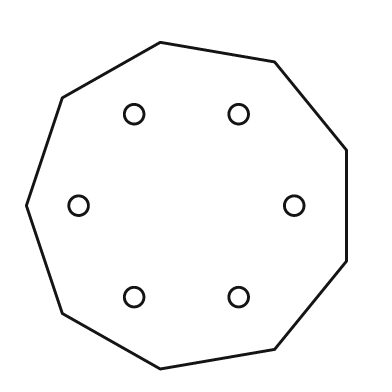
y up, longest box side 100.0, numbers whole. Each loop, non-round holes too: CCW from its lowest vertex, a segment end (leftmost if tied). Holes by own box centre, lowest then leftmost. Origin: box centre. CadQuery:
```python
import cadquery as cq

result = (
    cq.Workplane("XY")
    .moveTo(-8.0, -50.0)
    .lineTo(27.0, -44.0)
    .lineTo(49.0, -17.0)
    .lineTo(49.0, 17.0)
    .lineTo(27.0, 44.0)
    .lineTo(-8.0, 50.0)
    .lineTo(-38.0, 33.0)
    .lineTo(-49.0, 0.0)
    .lineTo(-38.0, -33.0)
    .close()
    .moveTo(-16.0, -28.0)
    .circle(3.0)
    .moveTo(16.0, -28.0)
    .circle(3.0)
    .moveTo(-33.0, 0.0)
    .circle(3.0)
    .moveTo(33.0, 0.0)
    .circle(3.0)
    .moveTo(-16.0, 28.0)
    .circle(3.0)
    .moveTo(16.0, 28.0)
    .circle(3.0)
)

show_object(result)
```